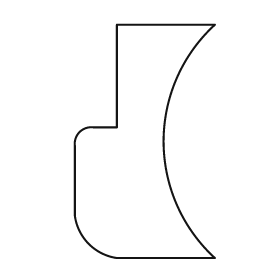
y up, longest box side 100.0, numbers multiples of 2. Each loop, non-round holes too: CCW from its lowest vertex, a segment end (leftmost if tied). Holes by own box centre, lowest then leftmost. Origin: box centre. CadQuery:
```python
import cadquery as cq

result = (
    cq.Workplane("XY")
    .moveTo(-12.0, -50.0)
    .lineTo(30.0, -50.0)
    .threePointArc((8.0, 0.0), (30.0, 50.0))
    .lineTo(-12.0, 50.0)
    .lineTo(-12.0, 6.0)
    .lineTo(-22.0, 6.0)
    .threePointArc((-28.0, 4.0), (-30.0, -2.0))
    .lineTo(-30.0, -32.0)
    .threePointArc((-24.0, -44.0), (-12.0, -50.0))
    .close()
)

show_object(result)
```